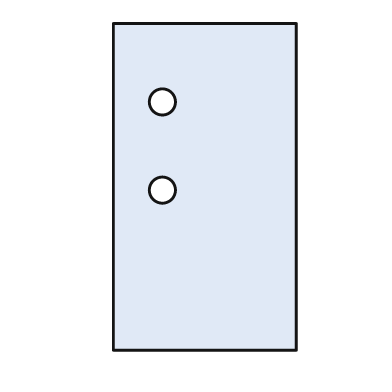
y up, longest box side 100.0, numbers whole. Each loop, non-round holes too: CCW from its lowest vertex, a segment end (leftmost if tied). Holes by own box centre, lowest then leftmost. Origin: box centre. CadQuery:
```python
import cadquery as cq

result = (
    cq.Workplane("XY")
    .moveTo(-28.0, -50.0)
    .lineTo(28.0, -50.0)
    .lineTo(28.0, 50.0)
    .lineTo(-28.0, 50.0)
    .close()
    .moveTo(-13.0, -1.0)
    .circle(4.0)
    .moveTo(-13.0, 26.0)
    .circle(4.0)
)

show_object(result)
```